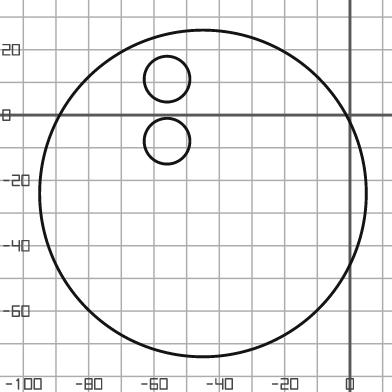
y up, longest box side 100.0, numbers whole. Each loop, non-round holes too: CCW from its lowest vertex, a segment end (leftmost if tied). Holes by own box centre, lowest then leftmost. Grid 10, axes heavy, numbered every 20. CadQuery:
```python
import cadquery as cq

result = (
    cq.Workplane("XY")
    .moveTo(-45.0, -24.0)
    .circle(50.0)
    .moveTo(-56.0, -8.0)
    .circle(7.0)
    .moveTo(-56.0, 11.0)
    .circle(7.0)
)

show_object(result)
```